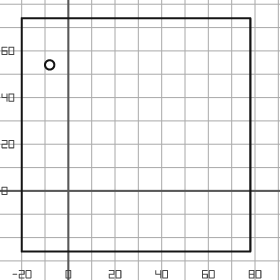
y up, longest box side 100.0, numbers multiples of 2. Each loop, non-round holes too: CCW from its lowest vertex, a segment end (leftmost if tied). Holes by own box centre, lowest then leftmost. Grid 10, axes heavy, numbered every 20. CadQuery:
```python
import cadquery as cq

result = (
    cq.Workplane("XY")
    .moveTo(-20.0, -26.0)
    .lineTo(78.0, -26.0)
    .lineTo(78.0, 74.0)
    .lineTo(-20.0, 74.0)
    .close()
    .moveTo(-8.0, 54.0)
    .circle(2.0)
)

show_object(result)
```